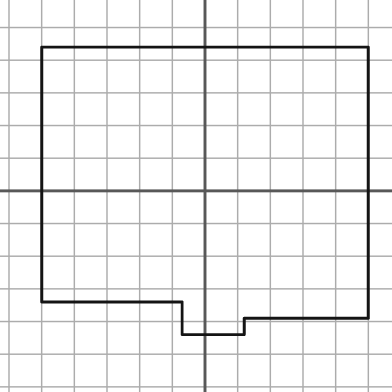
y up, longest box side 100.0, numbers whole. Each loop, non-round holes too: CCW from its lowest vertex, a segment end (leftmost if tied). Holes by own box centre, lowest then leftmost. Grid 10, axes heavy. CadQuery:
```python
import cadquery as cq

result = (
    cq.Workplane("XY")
    .moveTo(-7.0, -44.0)
    .lineTo(12.0, -44.0)
    .lineTo(12.0, -39.0)
    .lineTo(50.0, -39.0)
    .lineTo(50.0, 44.0)
    .lineTo(-50.0, 44.0)
    .lineTo(-50.0, -34.0)
    .lineTo(-7.0, -34.0)
    .close()
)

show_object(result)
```